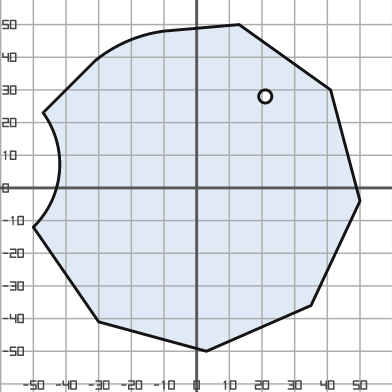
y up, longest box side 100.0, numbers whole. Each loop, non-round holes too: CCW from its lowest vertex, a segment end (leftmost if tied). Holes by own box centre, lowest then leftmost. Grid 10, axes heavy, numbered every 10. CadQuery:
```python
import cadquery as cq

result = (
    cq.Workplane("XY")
    .moveTo(3.0, -50.0)
    .lineTo(35.0, -36.0)
    .lineTo(50.0, -4.0)
    .lineTo(41.0, 30.0)
    .lineTo(13.0, 50.0)
    .lineTo(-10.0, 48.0)
    .threePointArc((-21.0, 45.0), (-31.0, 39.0))
    .lineTo(-47.0, 23.0)
    .threePointArc((-42.0, 5.0), (-50.0, -12.0))
    .lineTo(-30.0, -41.0)
    .close()
    .moveTo(21.0, 28.0)
    .circle(2.0)
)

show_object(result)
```